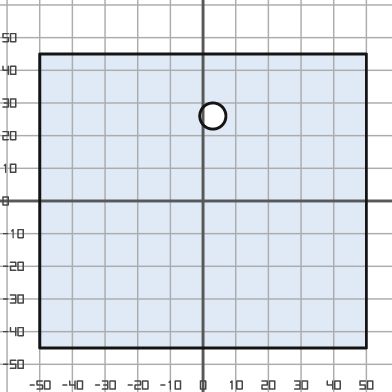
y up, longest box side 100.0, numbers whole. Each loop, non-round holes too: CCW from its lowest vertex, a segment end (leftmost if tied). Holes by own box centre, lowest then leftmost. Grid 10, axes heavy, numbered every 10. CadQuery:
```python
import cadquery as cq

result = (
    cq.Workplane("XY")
    .moveTo(-50.0, -45.0)
    .lineTo(50.0, -45.0)
    .lineTo(50.0, 45.0)
    .lineTo(-50.0, 45.0)
    .close()
    .moveTo(3.0, 26.0)
    .circle(4.0)
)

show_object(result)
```